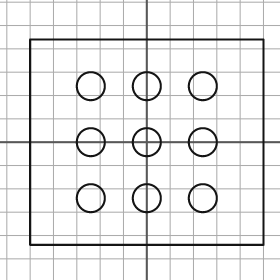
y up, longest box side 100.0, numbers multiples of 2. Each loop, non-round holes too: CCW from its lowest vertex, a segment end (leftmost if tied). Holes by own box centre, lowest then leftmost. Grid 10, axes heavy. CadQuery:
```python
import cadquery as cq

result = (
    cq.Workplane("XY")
    .moveTo(-50.0, -44.0)
    .lineTo(50.0, -44.0)
    .lineTo(50.0, 44.0)
    .lineTo(-50.0, 44.0)
    .close()
    .moveTo(-24.0, -24.0)
    .circle(6.0)
    .moveTo(0.0, -24.0)
    .circle(6.0)
    .moveTo(24.0, -24.0)
    .circle(6.0)
    .moveTo(-24.0, 0.0)
    .circle(6.0)
    .moveTo(0.0, 0.0)
    .circle(6.0)
    .moveTo(24.0, 0.0)
    .circle(6.0)
    .moveTo(-24.0, 24.0)
    .circle(6.0)
    .moveTo(0.0, 24.0)
    .circle(6.0)
    .moveTo(24.0, 24.0)
    .circle(6.0)
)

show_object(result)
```